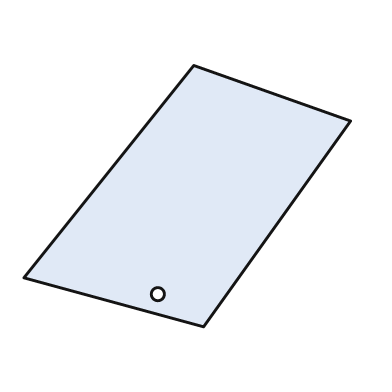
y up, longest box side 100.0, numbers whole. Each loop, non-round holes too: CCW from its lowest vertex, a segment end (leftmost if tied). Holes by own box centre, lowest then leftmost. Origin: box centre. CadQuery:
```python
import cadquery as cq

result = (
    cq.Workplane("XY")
    .moveTo(5.0, -40.0)
    .lineTo(50.0, 23.0)
    .lineTo(2.0, 40.0)
    .lineTo(-50.0, -25.0)
    .close()
    .moveTo(-9.0, -30.0)
    .circle(2.0)
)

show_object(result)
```